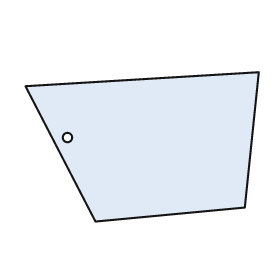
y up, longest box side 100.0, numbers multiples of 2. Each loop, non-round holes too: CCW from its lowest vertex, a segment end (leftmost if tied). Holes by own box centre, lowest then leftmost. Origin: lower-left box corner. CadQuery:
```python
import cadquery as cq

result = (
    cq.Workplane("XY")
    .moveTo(30.0, 0.0)
    .lineTo(94.0, 6.0)
    .lineTo(100.0, 64.0)
    .lineTo(0.0, 58.0)
    .close()
    .moveTo(18.0, 36.0)
    .circle(2.0)
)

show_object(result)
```